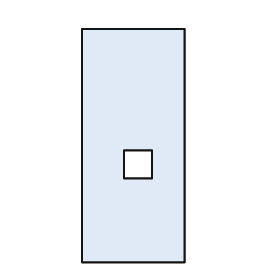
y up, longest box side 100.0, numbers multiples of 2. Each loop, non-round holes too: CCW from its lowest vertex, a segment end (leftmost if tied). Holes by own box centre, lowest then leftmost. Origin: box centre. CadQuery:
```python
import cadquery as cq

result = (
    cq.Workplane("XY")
    .moveTo(-22.0, -50.0)
    .lineTo(22.0, -50.0)
    .lineTo(22.0, 50.0)
    .lineTo(-22.0, 50.0)
    .close()
    .moveTo(-4.0, -14.0)
    .lineTo(8.0, -14.0)
    .lineTo(8.0, -2.0)
    .lineTo(-4.0, -2.0)
    .close()
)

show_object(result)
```